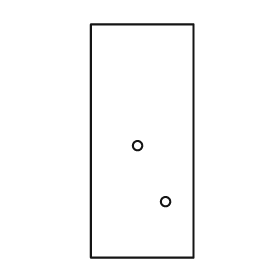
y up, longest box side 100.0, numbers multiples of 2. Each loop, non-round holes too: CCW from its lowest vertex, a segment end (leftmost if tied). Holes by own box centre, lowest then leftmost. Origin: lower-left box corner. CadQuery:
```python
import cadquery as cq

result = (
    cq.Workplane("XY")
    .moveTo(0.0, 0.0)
    .lineTo(44.0, 0.0)
    .lineTo(44.0, 100.0)
    .lineTo(0.0, 100.0)
    .close()
    .moveTo(32.0, 24.0)
    .circle(2.0)
    .moveTo(20.0, 48.0)
    .circle(2.0)
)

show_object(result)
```